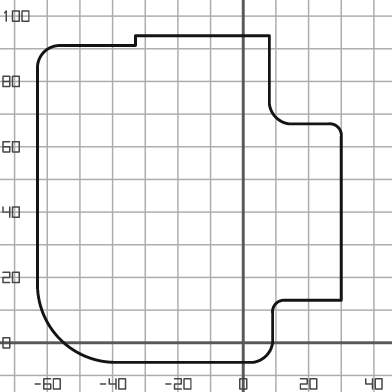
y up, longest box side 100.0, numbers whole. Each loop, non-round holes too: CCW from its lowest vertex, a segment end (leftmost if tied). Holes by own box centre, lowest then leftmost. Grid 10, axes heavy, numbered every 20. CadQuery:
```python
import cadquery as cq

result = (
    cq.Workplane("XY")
    .moveTo(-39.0, -6.0)
    .lineTo(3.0, -6.0)
    .threePointArc((7.0, -4.0), (9.0, 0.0))
    .lineTo(9.0, 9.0)
    .threePointArc((10.0, 12.0), (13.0, 13.0))
    .lineTo(30.0, 13.0)
    .lineTo(30.0, 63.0)
    .threePointArc((29.0, 66.0), (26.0, 67.0))
    .lineTo(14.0, 67.0)
    .threePointArc((10.0, 69.0), (8.0, 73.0))
    .lineTo(8.0, 94.0)
    .lineTo(-33.0, 94.0)
    .lineTo(-33.0, 91.0)
    .lineTo(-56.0, 91.0)
    .threePointArc((-61.0, 89.0), (-63.0, 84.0))
    .lineTo(-63.0, 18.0)
    .threePointArc((-56.0, 1.0), (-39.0, -6.0))
    .close()
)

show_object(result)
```